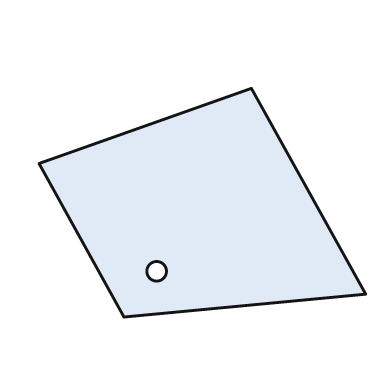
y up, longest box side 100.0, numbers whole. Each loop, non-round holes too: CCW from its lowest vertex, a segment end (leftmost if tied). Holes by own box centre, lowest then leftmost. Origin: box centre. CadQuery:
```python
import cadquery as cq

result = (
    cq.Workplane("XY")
    .moveTo(-24.0, -35.0)
    .lineTo(50.0, -28.0)
    .lineTo(15.0, 35.0)
    .lineTo(-50.0, 12.0)
    .close()
    .moveTo(-14.0, -21.0)
    .circle(3.0)
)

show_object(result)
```